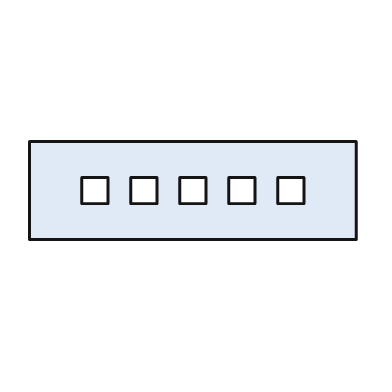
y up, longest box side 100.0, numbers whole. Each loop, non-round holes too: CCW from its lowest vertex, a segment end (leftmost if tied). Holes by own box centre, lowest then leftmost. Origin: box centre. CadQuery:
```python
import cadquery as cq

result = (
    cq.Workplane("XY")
    .moveTo(-50.0, -15.0)
    .lineTo(50.0, -15.0)
    .lineTo(50.0, 15.0)
    .lineTo(-50.0, 15.0)
    .close()
    .moveTo(-34.0, -4.0)
    .lineTo(-26.0, -4.0)
    .lineTo(-26.0, 4.0)
    .lineTo(-34.0, 4.0)
    .close()
    .moveTo(-19.0, -4.0)
    .lineTo(-11.0, -4.0)
    .lineTo(-11.0, 4.0)
    .lineTo(-19.0, 4.0)
    .close()
    .moveTo(-4.0, -4.0)
    .lineTo(4.0, -4.0)
    .lineTo(4.0, 4.0)
    .lineTo(-4.0, 4.0)
    .close()
    .moveTo(11.0, -4.0)
    .lineTo(19.0, -4.0)
    .lineTo(19.0, 4.0)
    .lineTo(11.0, 4.0)
    .close()
    .moveTo(26.0, -4.0)
    .lineTo(34.0, -4.0)
    .lineTo(34.0, 4.0)
    .lineTo(26.0, 4.0)
    .close()
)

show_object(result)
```